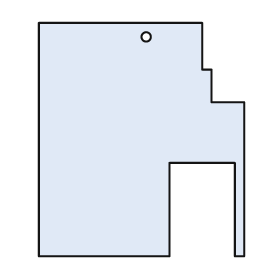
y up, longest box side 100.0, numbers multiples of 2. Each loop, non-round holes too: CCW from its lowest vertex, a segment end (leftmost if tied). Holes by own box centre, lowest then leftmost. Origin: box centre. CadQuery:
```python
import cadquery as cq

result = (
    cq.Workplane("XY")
    .moveTo(-44.0, -50.0)
    .lineTo(12.0, -50.0)
    .lineTo(12.0, -10.0)
    .lineTo(40.0, -10.0)
    .lineTo(40.0, -50.0)
    .lineTo(44.0, -50.0)
    .lineTo(44.0, 16.0)
    .lineTo(30.0, 16.0)
    .lineTo(30.0, 30.0)
    .lineTo(26.0, 30.0)
    .lineTo(26.0, 50.0)
    .lineTo(-44.0, 50.0)
    .close()
    .moveTo(2.0, 44.0)
    .circle(2.0)
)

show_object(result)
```